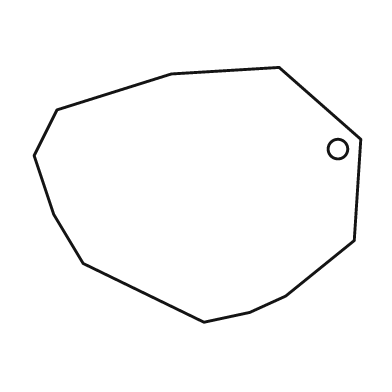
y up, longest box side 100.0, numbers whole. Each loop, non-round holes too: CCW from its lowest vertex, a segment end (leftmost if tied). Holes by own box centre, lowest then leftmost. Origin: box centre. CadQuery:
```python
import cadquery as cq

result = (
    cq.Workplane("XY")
    .moveTo(2.0, -39.0)
    .lineTo(16.0, -36.0)
    .lineTo(27.0, -31.0)
    .lineTo(48.0, -14.0)
    .lineTo(50.0, 17.0)
    .lineTo(25.0, 39.0)
    .lineTo(-8.0, 37.0)
    .lineTo(-43.0, 26.0)
    .lineTo(-50.0, 12.0)
    .lineTo(-44.0, -6.0)
    .lineTo(-35.0, -21.0)
    .close()
    .moveTo(43.0, 14.0)
    .circle(3.0)
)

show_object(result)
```